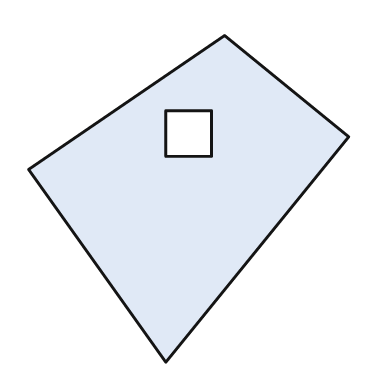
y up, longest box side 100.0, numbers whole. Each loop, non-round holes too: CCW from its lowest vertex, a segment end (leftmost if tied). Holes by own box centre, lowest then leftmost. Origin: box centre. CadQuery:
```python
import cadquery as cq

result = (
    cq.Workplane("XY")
    .moveTo(-7.0, -50.0)
    .lineTo(49.0, 19.0)
    .lineTo(11.0, 50.0)
    .lineTo(-49.0, 9.0)
    .close()
    .moveTo(-7.0, 13.0)
    .lineTo(7.0, 13.0)
    .lineTo(7.0, 27.0)
    .lineTo(-7.0, 27.0)
    .close()
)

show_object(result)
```